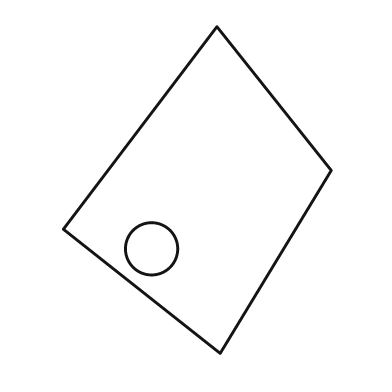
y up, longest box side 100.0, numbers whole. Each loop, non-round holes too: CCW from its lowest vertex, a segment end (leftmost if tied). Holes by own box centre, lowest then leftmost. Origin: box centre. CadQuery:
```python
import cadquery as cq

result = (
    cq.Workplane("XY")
    .moveTo(7.0, -50.0)
    .lineTo(41.0, 6.0)
    .lineTo(6.0, 50.0)
    .lineTo(-41.0, -12.0)
    .close()
    .moveTo(-14.0, -18.0)
    .circle(8.0)
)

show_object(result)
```